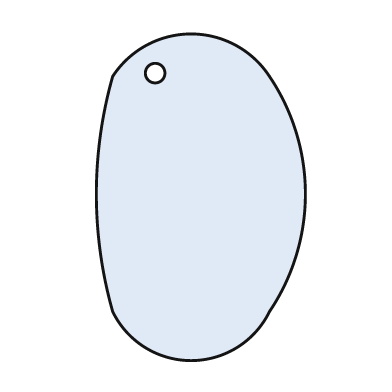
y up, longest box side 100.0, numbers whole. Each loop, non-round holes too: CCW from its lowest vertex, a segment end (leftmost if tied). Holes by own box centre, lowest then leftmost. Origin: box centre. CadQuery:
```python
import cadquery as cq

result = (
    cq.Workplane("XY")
    .moveTo(-27.0, -35.0)
    .threePointArc((-3.0, -50.0), (21.0, -35.0))
    .threePointArc((32.0, 1.0), (21.0, 37.0))
    .threePointArc((-3.0, 50.0), (-27.0, 37.0))
    .threePointArc((-32.0, 1.0), (-27.0, -35.0))
    .close()
    .moveTo(-14.0, 38.0)
    .circle(3.0)
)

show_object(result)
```